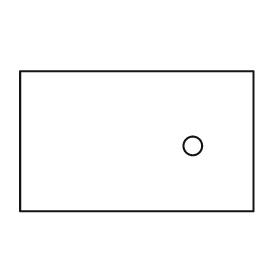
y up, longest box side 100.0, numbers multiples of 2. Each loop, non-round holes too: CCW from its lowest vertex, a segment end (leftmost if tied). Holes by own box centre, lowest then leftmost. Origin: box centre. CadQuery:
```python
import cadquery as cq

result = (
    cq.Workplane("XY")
    .moveTo(-50.0, -30.0)
    .lineTo(50.0, -30.0)
    .lineTo(50.0, 30.0)
    .lineTo(-50.0, 30.0)
    .close()
    .moveTo(24.0, -2.0)
    .circle(4.0)
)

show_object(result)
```